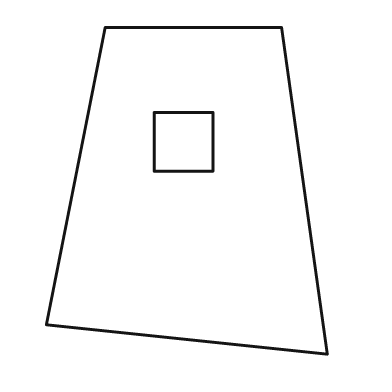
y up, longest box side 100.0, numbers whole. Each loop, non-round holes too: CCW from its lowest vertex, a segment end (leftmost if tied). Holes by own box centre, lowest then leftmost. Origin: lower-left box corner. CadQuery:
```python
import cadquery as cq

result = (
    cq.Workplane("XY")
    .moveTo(86.0, 0.0)
    .lineTo(72.0, 100.0)
    .lineTo(18.0, 100.0)
    .lineTo(0.0, 9.0)
    .close()
    .moveTo(33.0, 56.0)
    .lineTo(51.0, 56.0)
    .lineTo(51.0, 74.0)
    .lineTo(33.0, 74.0)
    .close()
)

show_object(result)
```